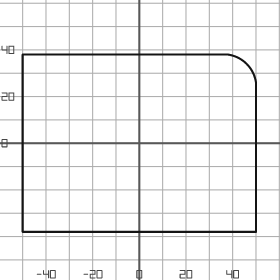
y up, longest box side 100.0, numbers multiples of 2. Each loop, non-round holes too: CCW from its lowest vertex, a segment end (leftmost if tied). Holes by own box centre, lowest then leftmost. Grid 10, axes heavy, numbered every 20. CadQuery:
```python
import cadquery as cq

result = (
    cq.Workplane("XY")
    .moveTo(-50.0, -38.0)
    .lineTo(50.0, -38.0)
    .lineTo(50.0, 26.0)
    .threePointArc((46.0, 34.0), (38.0, 38.0))
    .lineTo(-50.0, 38.0)
    .close()
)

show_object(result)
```